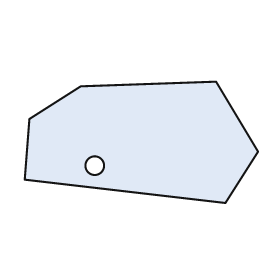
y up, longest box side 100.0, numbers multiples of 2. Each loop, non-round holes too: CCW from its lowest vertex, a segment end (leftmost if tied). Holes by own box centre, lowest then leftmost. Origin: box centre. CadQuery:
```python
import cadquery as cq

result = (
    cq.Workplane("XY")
    .moveTo(36.0, -26.0)
    .lineTo(50.0, -4.0)
    .lineTo(32.0, 26.0)
    .lineTo(-26.0, 24.0)
    .lineTo(-48.0, 10.0)
    .lineTo(-50.0, -16.0)
    .close()
    .moveTo(-20.0, -10.0)
    .circle(4.0)
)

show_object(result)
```